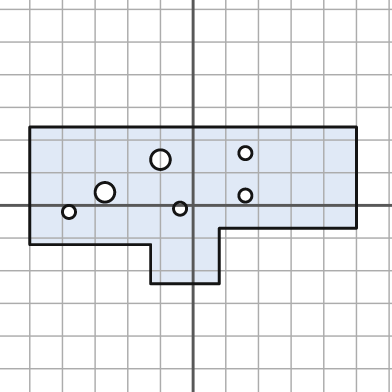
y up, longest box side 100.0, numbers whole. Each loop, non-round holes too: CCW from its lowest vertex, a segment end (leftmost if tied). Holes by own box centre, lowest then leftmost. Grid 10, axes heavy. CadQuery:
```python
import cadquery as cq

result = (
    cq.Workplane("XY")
    .moveTo(-13.0, -24.0)
    .lineTo(8.0, -24.0)
    .lineTo(8.0, -7.0)
    .lineTo(50.0, -7.0)
    .lineTo(50.0, 24.0)
    .lineTo(-50.0, 24.0)
    .lineTo(-50.0, -12.0)
    .lineTo(-13.0, -12.0)
    .close()
    .moveTo(-38.0, -2.0)
    .circle(2.0)
    .moveTo(-4.0, -1.0)
    .circle(2.0)
    .moveTo(16.0, 3.0)
    .circle(2.0)
    .moveTo(-27.0, 4.0)
    .circle(3.0)
    .moveTo(-10.0, 14.0)
    .circle(3.0)
    .moveTo(16.0, 16.0)
    .circle(2.0)
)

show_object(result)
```